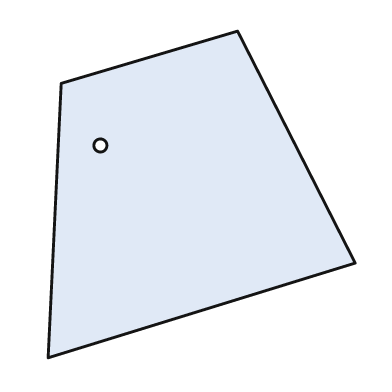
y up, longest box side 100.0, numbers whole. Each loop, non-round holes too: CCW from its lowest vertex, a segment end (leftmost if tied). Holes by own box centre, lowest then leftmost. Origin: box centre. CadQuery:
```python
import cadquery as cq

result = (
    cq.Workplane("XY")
    .moveTo(-47.0, -50.0)
    .lineTo(47.0, -21.0)
    .lineTo(11.0, 50.0)
    .lineTo(-43.0, 34.0)
    .close()
    .moveTo(-31.0, 15.0)
    .circle(2.0)
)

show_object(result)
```